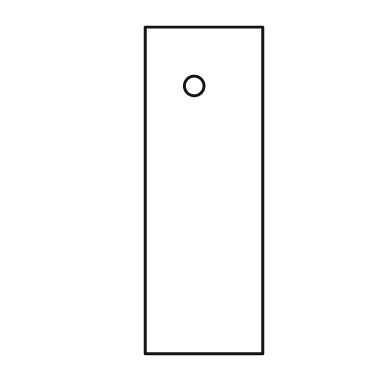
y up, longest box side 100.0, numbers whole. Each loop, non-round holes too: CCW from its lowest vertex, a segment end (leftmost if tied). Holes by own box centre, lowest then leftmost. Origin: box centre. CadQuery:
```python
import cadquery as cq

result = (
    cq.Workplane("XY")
    .moveTo(-18.0, -50.0)
    .lineTo(18.0, -50.0)
    .lineTo(18.0, 50.0)
    .lineTo(-18.0, 50.0)
    .close()
    .moveTo(-3.0, 32.0)
    .circle(3.0)
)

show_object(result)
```